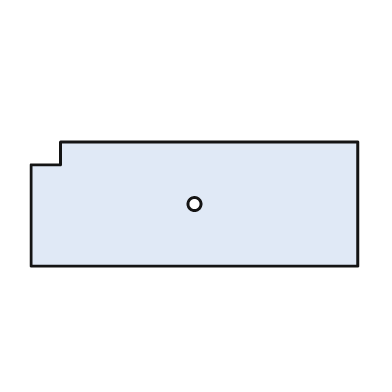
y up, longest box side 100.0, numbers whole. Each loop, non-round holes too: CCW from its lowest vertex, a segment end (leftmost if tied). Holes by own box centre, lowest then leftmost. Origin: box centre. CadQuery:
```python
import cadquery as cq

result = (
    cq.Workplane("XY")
    .moveTo(-50.0, -19.0)
    .lineTo(50.0, -19.0)
    .lineTo(50.0, 19.0)
    .lineTo(-41.0, 19.0)
    .lineTo(-41.0, 12.0)
    .lineTo(-50.0, 12.0)
    .close()
    .moveTo(0.0, 0.0)
    .circle(2.0)
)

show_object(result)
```